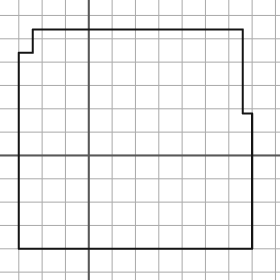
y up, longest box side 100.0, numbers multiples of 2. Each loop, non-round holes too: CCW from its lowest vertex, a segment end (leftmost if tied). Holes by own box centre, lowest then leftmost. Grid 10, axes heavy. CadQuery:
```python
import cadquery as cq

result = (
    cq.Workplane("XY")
    .moveTo(-30.0, -40.0)
    .lineTo(70.0, -40.0)
    .lineTo(70.0, 18.0)
    .lineTo(66.0, 18.0)
    .lineTo(66.0, 54.0)
    .lineTo(-24.0, 54.0)
    .lineTo(-24.0, 44.0)
    .lineTo(-30.0, 44.0)
    .close()
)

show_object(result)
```